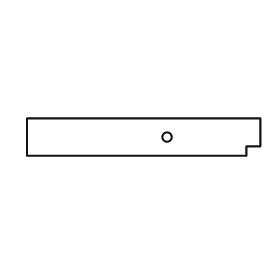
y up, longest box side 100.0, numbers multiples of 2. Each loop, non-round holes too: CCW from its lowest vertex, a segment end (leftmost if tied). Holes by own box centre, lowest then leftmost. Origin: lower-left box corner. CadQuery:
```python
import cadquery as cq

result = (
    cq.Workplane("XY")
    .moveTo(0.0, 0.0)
    .lineTo(94.0, 0.0)
    .lineTo(94.0, 4.0)
    .lineTo(100.0, 4.0)
    .lineTo(100.0, 16.0)
    .lineTo(0.0, 16.0)
    .close()
    .moveTo(60.0, 8.0)
    .circle(2.0)
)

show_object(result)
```